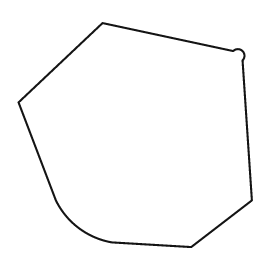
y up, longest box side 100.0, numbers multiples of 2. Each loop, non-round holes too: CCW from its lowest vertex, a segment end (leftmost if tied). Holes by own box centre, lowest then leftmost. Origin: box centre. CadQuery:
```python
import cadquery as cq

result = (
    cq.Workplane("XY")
    .moveTo(24.0, -48.0)
    .lineTo(50.0, -28.0)
    .lineTo(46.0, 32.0)
    .threePointArc((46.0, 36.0), (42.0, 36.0))
    .lineTo(-14.0, 48.0)
    .lineTo(-50.0, 14.0)
    .lineTo(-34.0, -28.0)
    .threePointArc((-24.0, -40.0), (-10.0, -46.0))
    .close()
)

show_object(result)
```